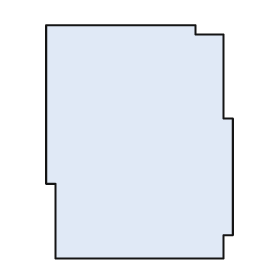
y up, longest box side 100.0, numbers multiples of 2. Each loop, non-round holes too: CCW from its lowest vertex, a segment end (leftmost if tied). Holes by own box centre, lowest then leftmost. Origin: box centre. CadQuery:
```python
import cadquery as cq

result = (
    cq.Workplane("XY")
    .moveTo(-36.0, -50.0)
    .lineTo(36.0, -50.0)
    .lineTo(36.0, -40.0)
    .lineTo(40.0, -40.0)
    .lineTo(40.0, 10.0)
    .lineTo(36.0, 10.0)
    .lineTo(36.0, 46.0)
    .lineTo(24.0, 46.0)
    .lineTo(24.0, 50.0)
    .lineTo(-40.0, 50.0)
    .lineTo(-40.0, -18.0)
    .lineTo(-36.0, -18.0)
    .close()
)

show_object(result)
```